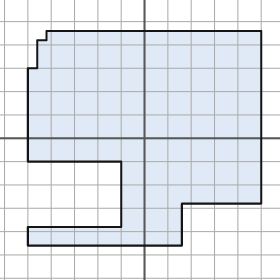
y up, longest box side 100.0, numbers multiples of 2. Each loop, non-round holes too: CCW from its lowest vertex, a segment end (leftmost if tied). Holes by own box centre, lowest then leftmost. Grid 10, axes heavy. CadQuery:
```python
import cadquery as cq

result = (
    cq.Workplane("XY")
    .moveTo(-50.0, -46.0)
    .lineTo(16.0, -46.0)
    .lineTo(16.0, -28.0)
    .lineTo(50.0, -28.0)
    .lineTo(50.0, 46.0)
    .lineTo(-42.0, 46.0)
    .lineTo(-42.0, 42.0)
    .lineTo(-46.0, 42.0)
    .lineTo(-46.0, 30.0)
    .lineTo(-50.0, 30.0)
    .lineTo(-50.0, -10.0)
    .lineTo(-10.0, -10.0)
    .lineTo(-10.0, -38.0)
    .lineTo(-50.0, -38.0)
    .close()
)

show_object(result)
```